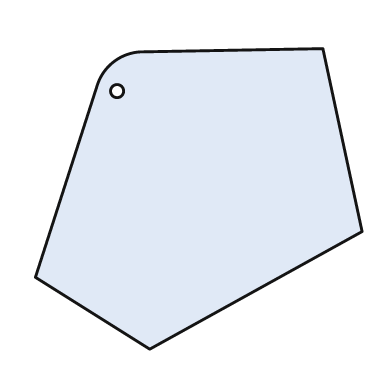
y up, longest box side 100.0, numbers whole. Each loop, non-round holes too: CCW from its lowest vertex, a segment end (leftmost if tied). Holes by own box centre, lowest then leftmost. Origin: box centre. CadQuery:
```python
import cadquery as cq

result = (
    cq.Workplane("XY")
    .moveTo(-15.0, -46.0)
    .lineTo(50.0, -10.0)
    .lineTo(38.0, 46.0)
    .lineTo(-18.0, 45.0)
    .threePointArc((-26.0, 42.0), (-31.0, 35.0))
    .lineTo(-50.0, -24.0)
    .close()
    .moveTo(-25.0, 33.0)
    .circle(2.0)
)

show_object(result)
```